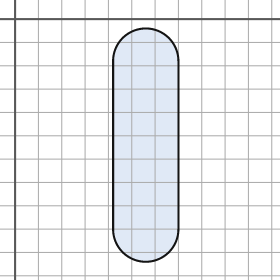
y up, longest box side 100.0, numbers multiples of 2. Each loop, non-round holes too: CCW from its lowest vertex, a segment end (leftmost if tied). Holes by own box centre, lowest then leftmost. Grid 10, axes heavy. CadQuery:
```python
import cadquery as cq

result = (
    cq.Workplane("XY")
    .moveTo(42.0, -90.0)
    .threePointArc((56.0, -104.0), (70.0, -90.0))
    .lineTo(70.0, -18.0)
    .threePointArc((56.0, -4.0), (42.0, -18.0))
    .close()
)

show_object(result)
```